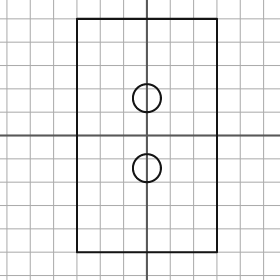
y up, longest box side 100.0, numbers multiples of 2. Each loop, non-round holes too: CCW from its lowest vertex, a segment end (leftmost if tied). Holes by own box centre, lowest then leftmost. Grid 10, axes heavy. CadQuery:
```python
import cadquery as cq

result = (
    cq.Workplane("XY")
    .moveTo(-30.0, -50.0)
    .lineTo(30.0, -50.0)
    .lineTo(30.0, 50.0)
    .lineTo(-30.0, 50.0)
    .close()
    .moveTo(0.0, -14.0)
    .circle(6.0)
    .moveTo(0.0, 16.0)
    .circle(6.0)
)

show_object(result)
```